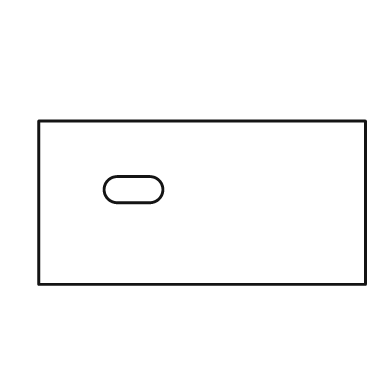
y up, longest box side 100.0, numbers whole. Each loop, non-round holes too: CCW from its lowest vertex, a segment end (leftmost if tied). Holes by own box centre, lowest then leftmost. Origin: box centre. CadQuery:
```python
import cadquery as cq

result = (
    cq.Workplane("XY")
    .moveTo(-50.0, -25.0)
    .lineTo(50.0, -25.0)
    .lineTo(50.0, 25.0)
    .lineTo(-50.0, 25.0)
    .close()
    .moveTo(-26.0, 0.0)
    .lineTo(-16.0, 0.0)
    .threePointArc((-12.0, 4.0), (-16.0, 8.0))
    .lineTo(-26.0, 8.0)
    .threePointArc((-30.0, 4.0), (-26.0, 0.0))
    .close()
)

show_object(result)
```